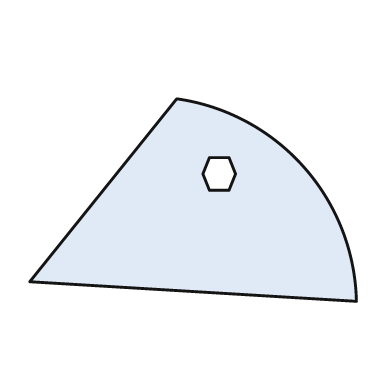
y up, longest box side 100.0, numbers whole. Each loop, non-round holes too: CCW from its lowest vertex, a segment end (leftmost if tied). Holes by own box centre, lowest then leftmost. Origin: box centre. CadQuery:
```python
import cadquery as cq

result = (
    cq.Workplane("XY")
    .moveTo(50.0, -31.0)
    .threePointArc((34.0, 10.0), (-5.0, 31.0))
    .lineTo(-50.0, -25.0)
    .close()
    .moveTo(5.0, 3.0)
    .lineTo(11.0, 3.0)
    .lineTo(13.0, 8.0)
    .lineTo(11.0, 13.0)
    .lineTo(5.0, 13.0)
    .lineTo(3.0, 8.0)
    .close()
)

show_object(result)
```